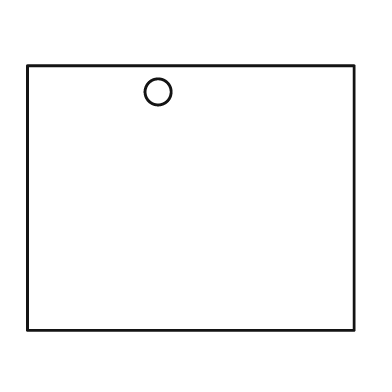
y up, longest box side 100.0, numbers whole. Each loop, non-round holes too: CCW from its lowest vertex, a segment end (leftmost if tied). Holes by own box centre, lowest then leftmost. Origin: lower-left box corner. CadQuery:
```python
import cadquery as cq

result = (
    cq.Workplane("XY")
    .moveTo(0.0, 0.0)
    .lineTo(100.0, 0.0)
    .lineTo(100.0, 81.0)
    .lineTo(0.0, 81.0)
    .close()
    .moveTo(40.0, 73.0)
    .circle(4.0)
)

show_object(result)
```